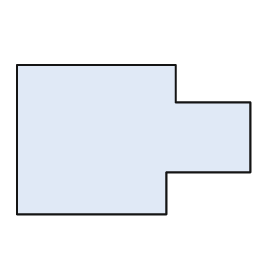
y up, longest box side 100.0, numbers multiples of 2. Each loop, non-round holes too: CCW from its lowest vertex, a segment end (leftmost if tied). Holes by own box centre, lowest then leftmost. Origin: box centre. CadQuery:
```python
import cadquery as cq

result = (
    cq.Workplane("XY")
    .moveTo(-50.0, -32.0)
    .lineTo(14.0, -32.0)
    .lineTo(14.0, -14.0)
    .lineTo(50.0, -14.0)
    .lineTo(50.0, 16.0)
    .lineTo(18.0, 16.0)
    .lineTo(18.0, 32.0)
    .lineTo(-50.0, 32.0)
    .close()
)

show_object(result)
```